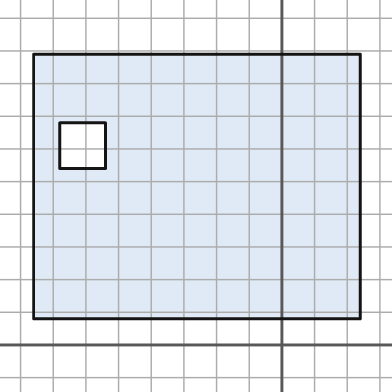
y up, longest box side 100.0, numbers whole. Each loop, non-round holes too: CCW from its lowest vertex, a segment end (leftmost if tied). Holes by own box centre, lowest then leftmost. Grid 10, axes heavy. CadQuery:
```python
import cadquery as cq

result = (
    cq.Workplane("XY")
    .moveTo(-76.0, 8.0)
    .lineTo(24.0, 8.0)
    .lineTo(24.0, 89.0)
    .lineTo(-76.0, 89.0)
    .close()
    .moveTo(-68.0, 54.0)
    .lineTo(-54.0, 54.0)
    .lineTo(-54.0, 68.0)
    .lineTo(-68.0, 68.0)
    .close()
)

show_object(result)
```